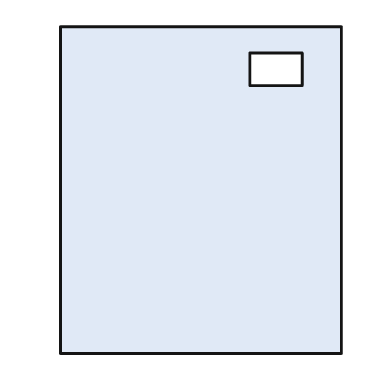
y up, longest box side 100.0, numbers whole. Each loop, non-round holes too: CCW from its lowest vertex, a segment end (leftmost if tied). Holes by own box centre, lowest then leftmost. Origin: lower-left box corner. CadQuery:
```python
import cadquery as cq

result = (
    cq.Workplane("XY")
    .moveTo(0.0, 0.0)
    .lineTo(86.0, 0.0)
    .lineTo(86.0, 100.0)
    .lineTo(0.0, 100.0)
    .close()
    .moveTo(58.0, 82.0)
    .lineTo(74.0, 82.0)
    .lineTo(74.0, 92.0)
    .lineTo(58.0, 92.0)
    .close()
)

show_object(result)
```